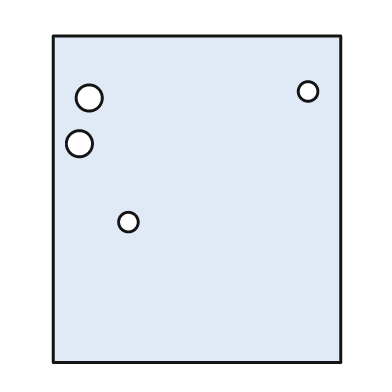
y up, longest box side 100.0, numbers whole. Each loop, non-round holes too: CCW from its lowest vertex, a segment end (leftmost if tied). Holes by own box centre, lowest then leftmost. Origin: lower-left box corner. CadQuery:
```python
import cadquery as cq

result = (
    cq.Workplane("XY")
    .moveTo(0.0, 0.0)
    .lineTo(88.0, 0.0)
    .lineTo(88.0, 100.0)
    .lineTo(0.0, 100.0)
    .close()
    .moveTo(23.0, 43.0)
    .circle(3.0)
    .moveTo(8.0, 67.0)
    .circle(4.0)
    .moveTo(11.0, 81.0)
    .circle(4.0)
    .moveTo(78.0, 83.0)
    .circle(3.0)
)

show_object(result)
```